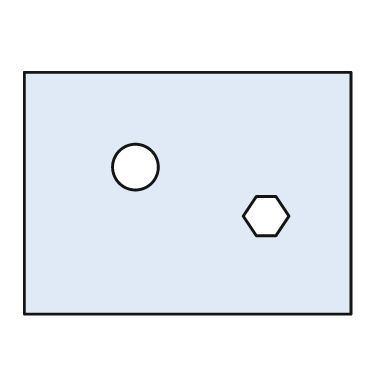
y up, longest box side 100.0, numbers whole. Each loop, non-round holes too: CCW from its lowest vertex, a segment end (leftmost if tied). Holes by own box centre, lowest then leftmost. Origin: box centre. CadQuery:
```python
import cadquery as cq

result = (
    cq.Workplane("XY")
    .moveTo(-50.0, -37.0)
    .lineTo(50.0, -37.0)
    .lineTo(50.0, 37.0)
    .lineTo(-50.0, 37.0)
    .close()
    .moveTo(21.0, -13.0)
    .lineTo(27.0, -13.0)
    .lineTo(31.0, -7.0)
    .lineTo(27.0, -1.0)
    .lineTo(21.0, -1.0)
    .lineTo(17.0, -7.0)
    .close()
    .moveTo(-16.0, 8.0)
    .circle(7.0)
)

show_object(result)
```